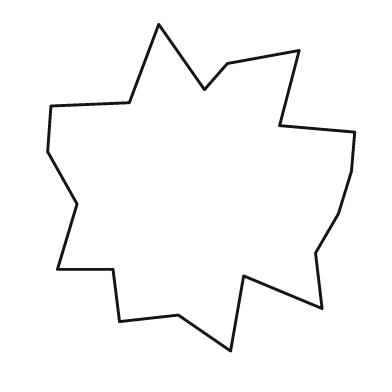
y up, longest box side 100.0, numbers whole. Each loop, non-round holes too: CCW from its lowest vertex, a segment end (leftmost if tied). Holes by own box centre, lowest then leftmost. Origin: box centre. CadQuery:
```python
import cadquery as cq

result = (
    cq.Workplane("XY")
    .moveTo(9.0, -50.0)
    .lineTo(13.0, -27.0)
    .lineTo(37.0, -37.0)
    .lineTo(35.0, -20.0)
    .lineTo(42.0, -8.0)
    .lineTo(46.0, 5.0)
    .lineTo(47.0, 17.0)
    .lineTo(24.0, 19.0)
    .lineTo(30.0, 42.0)
    .lineTo(8.0, 38.0)
    .lineTo(1.0, 30.0)
    .lineTo(-13.0, 50.0)
    .lineTo(-22.0, 26.0)
    .lineTo(-46.0, 25.0)
    .lineTo(-47.0, 11.0)
    .lineTo(-38.0, -5.0)
    .lineTo(-44.0, -25.0)
    .lineTo(-27.0, -25.0)
    .lineTo(-25.0, -41.0)
    .lineTo(-7.0, -39.0)
    .close()
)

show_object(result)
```